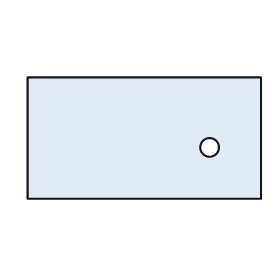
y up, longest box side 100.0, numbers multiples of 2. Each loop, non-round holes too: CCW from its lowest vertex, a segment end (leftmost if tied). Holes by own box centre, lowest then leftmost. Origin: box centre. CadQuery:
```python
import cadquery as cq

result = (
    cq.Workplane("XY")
    .moveTo(-50.0, -26.0)
    .lineTo(50.0, -26.0)
    .lineTo(50.0, 26.0)
    .lineTo(-50.0, 26.0)
    .close()
    .moveTo(28.0, -4.0)
    .circle(4.0)
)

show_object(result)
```